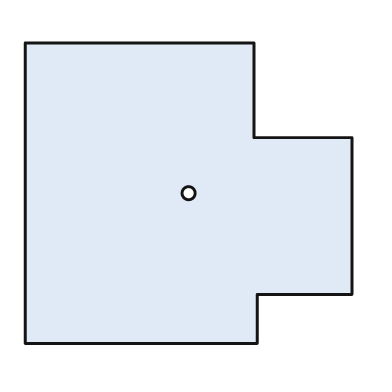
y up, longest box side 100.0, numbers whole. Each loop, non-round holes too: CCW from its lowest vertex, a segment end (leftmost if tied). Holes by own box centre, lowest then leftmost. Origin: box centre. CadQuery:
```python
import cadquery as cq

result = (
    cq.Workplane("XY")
    .moveTo(-50.0, -46.0)
    .lineTo(21.0, -46.0)
    .lineTo(21.0, -31.0)
    .lineTo(50.0, -31.0)
    .lineTo(50.0, 17.0)
    .lineTo(20.0, 17.0)
    .lineTo(20.0, 46.0)
    .lineTo(-50.0, 46.0)
    .close()
    .moveTo(0.0, 0.0)
    .circle(2.0)
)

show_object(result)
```